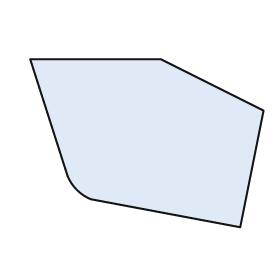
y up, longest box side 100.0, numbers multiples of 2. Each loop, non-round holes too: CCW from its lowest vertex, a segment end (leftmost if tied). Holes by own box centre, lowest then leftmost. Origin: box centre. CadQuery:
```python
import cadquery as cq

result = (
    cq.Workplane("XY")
    .moveTo(40.0, -36.0)
    .lineTo(50.0, 14.0)
    .lineTo(6.0, 36.0)
    .lineTo(-50.0, 36.0)
    .lineTo(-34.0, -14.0)
    .threePointArc((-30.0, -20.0), (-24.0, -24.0))
    .close()
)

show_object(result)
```